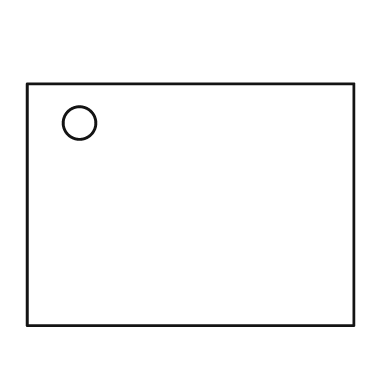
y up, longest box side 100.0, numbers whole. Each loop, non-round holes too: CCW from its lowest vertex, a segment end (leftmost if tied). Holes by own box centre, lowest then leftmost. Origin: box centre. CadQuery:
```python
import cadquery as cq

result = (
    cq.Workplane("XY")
    .moveTo(-50.0, -37.0)
    .lineTo(50.0, -37.0)
    .lineTo(50.0, 37.0)
    .lineTo(-50.0, 37.0)
    .close()
    .moveTo(-34.0, 25.0)
    .circle(5.0)
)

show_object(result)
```